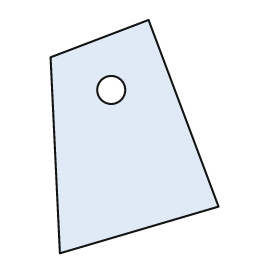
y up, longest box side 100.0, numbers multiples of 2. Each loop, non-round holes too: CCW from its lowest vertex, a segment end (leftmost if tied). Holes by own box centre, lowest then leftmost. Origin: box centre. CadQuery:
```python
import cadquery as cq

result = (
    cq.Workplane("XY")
    .moveTo(-32.0, -50.0)
    .lineTo(36.0, -30.0)
    .lineTo(6.0, 50.0)
    .lineTo(-36.0, 34.0)
    .close()
    .moveTo(-10.0, 20.0)
    .circle(6.0)
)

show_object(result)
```